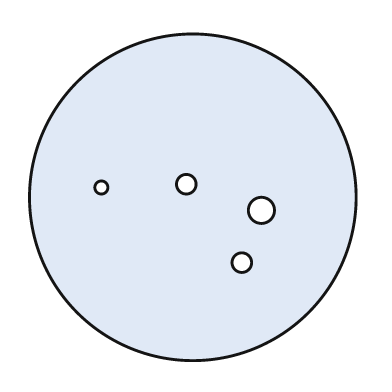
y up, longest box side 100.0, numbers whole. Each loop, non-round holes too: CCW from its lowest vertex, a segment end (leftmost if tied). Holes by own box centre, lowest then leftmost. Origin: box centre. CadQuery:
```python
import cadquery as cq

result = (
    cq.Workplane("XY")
    .moveTo(0.0, 0.0)
    .circle(50.0)
    .moveTo(15.0, -20.0)
    .circle(3.0)
    .moveTo(21.0, -4.0)
    .circle(4.0)
    .moveTo(-28.0, 3.0)
    .circle(2.0)
    .moveTo(-2.0, 4.0)
    .circle(3.0)
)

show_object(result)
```